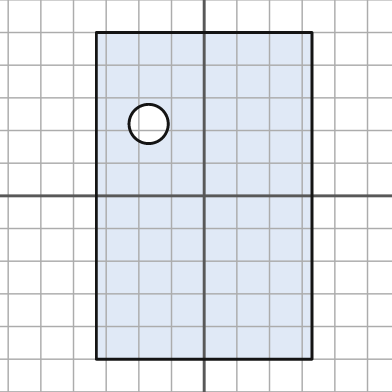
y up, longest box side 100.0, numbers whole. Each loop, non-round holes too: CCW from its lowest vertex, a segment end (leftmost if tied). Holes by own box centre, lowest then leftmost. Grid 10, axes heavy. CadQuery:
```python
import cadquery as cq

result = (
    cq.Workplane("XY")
    .moveTo(-33.0, -50.0)
    .lineTo(33.0, -50.0)
    .lineTo(33.0, 50.0)
    .lineTo(-33.0, 50.0)
    .close()
    .moveTo(-17.0, 22.0)
    .circle(6.0)
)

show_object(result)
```